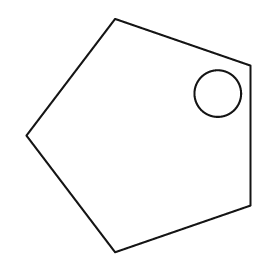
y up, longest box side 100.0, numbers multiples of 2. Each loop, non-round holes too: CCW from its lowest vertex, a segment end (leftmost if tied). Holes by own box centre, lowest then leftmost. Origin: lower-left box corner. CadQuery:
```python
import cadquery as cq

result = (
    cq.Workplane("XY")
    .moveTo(38.0, 0.0)
    .lineTo(96.0, 20.0)
    .lineTo(96.0, 80.0)
    .lineTo(38.0, 100.0)
    .lineTo(0.0, 50.0)
    .close()
    .moveTo(82.0, 68.0)
    .circle(10.0)
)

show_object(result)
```